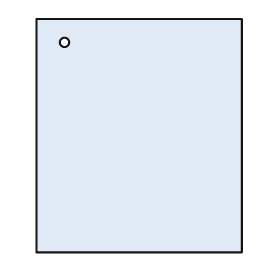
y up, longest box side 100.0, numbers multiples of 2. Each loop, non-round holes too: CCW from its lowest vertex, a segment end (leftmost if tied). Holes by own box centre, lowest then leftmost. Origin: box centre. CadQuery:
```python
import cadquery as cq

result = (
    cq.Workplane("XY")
    .moveTo(-44.0, -50.0)
    .lineTo(44.0, -50.0)
    .lineTo(44.0, 50.0)
    .lineTo(-44.0, 50.0)
    .close()
    .moveTo(-32.0, 40.0)
    .circle(2.0)
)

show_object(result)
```